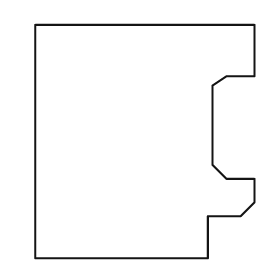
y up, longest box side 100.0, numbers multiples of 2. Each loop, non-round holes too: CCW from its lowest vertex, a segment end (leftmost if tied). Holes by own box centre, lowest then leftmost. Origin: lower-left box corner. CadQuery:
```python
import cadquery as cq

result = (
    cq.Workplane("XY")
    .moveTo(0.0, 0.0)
    .lineTo(74.0, 0.0)
    .lineTo(74.0, 18.0)
    .lineTo(88.0, 18.0)
    .lineTo(94.0, 24.0)
    .lineTo(94.0, 34.0)
    .lineTo(82.0, 34.0)
    .lineTo(76.0, 40.0)
    .lineTo(76.0, 74.0)
    .lineTo(82.0, 78.0)
    .lineTo(94.0, 78.0)
    .lineTo(94.0, 100.0)
    .lineTo(0.0, 100.0)
    .close()
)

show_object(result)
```